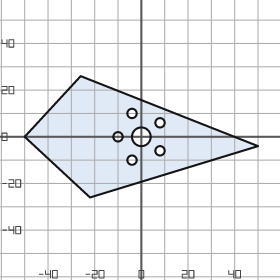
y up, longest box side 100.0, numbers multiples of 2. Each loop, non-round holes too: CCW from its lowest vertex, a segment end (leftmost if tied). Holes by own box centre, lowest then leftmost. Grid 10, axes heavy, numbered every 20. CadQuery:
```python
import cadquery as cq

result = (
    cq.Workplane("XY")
    .moveTo(-22.0, -26.0)
    .lineTo(50.0, -4.0)
    .lineTo(-26.0, 26.0)
    .lineTo(-50.0, 0.0)
    .close()
    .moveTo(-4.0, -10.0)
    .circle(2.0)
    .moveTo(8.0, -6.0)
    .circle(2.0)
    .moveTo(-10.0, 0.0)
    .circle(2.0)
    .moveTo(0.0, 0.0)
    .circle(4.0)
    .moveTo(8.0, 6.0)
    .circle(2.0)
    .moveTo(-4.0, 10.0)
    .circle(2.0)
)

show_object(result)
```